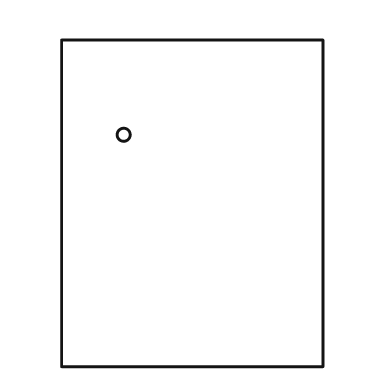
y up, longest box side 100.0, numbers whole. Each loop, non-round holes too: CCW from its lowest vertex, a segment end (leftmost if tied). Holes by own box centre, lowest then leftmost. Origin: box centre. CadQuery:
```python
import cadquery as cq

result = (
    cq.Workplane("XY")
    .moveTo(-40.0, -50.0)
    .lineTo(40.0, -50.0)
    .lineTo(40.0, 50.0)
    .lineTo(-40.0, 50.0)
    .close()
    .moveTo(-21.0, 21.0)
    .circle(2.0)
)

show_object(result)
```